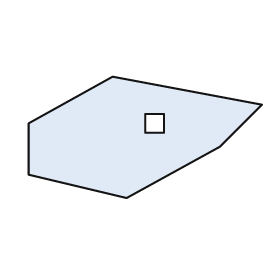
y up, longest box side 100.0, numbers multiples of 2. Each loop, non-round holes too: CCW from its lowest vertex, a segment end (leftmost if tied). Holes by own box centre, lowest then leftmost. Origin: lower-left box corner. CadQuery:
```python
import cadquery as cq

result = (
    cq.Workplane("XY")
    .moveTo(42.0, 0.0)
    .lineTo(82.0, 22.0)
    .lineTo(100.0, 40.0)
    .lineTo(36.0, 52.0)
    .lineTo(0.0, 32.0)
    .lineTo(0.0, 10.0)
    .close()
    .moveTo(50.0, 28.0)
    .lineTo(58.0, 28.0)
    .lineTo(58.0, 36.0)
    .lineTo(50.0, 36.0)
    .close()
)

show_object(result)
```